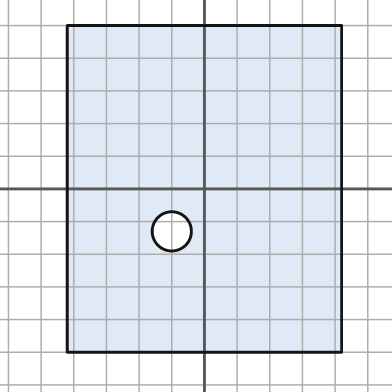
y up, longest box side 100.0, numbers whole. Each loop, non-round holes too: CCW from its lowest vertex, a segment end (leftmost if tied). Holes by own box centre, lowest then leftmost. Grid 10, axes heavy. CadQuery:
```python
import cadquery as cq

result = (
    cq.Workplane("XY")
    .moveTo(-42.0, -50.0)
    .lineTo(42.0, -50.0)
    .lineTo(42.0, 50.0)
    .lineTo(-42.0, 50.0)
    .close()
    .moveTo(-10.0, -13.0)
    .circle(6.0)
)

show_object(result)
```